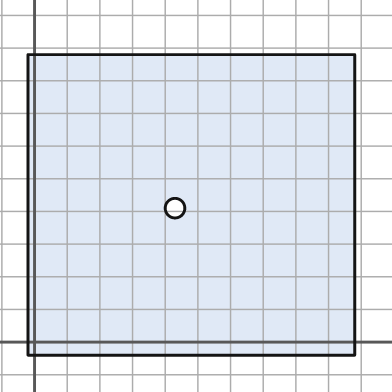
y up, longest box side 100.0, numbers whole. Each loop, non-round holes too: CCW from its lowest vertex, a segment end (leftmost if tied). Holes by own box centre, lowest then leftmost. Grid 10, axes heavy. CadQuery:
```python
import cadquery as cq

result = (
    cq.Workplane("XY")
    .moveTo(-2.0, -4.0)
    .lineTo(98.0, -4.0)
    .lineTo(98.0, 88.0)
    .lineTo(-2.0, 88.0)
    .close()
    .moveTo(43.0, 41.0)
    .circle(3.0)
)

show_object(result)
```